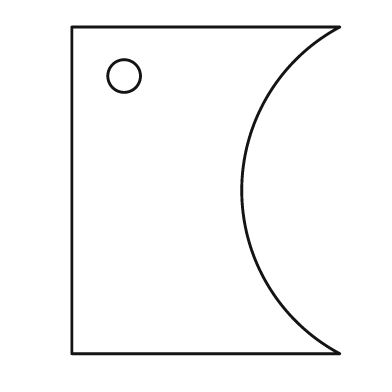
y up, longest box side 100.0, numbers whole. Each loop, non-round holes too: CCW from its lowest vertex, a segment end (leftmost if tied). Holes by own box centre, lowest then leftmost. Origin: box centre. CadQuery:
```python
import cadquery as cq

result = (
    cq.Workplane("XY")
    .moveTo(-41.0, -50.0)
    .lineTo(41.0, -50.0)
    .threePointArc((11.0, 0.0), (41.0, 50.0))
    .lineTo(-41.0, 50.0)
    .close()
    .moveTo(-25.0, 35.0)
    .circle(5.0)
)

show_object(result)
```